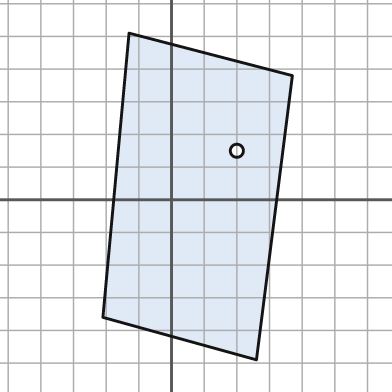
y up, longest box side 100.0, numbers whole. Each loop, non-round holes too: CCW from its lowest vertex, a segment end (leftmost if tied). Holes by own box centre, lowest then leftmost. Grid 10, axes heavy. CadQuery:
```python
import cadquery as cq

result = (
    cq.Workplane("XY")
    .moveTo(26.0, -49.0)
    .lineTo(37.0, 38.0)
    .lineTo(-13.0, 51.0)
    .lineTo(-21.0, -36.0)
    .close()
    .moveTo(20.0, 15.0)
    .circle(2.0)
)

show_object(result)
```